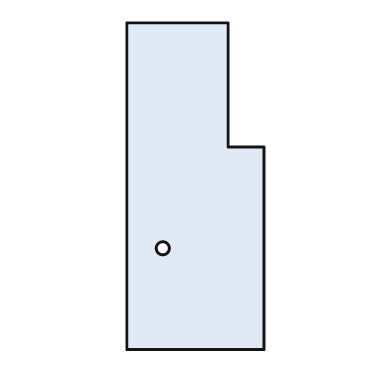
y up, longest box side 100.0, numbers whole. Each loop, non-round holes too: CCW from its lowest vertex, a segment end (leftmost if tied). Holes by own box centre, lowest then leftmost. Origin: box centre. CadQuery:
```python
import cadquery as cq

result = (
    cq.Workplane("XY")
    .moveTo(-21.0, -50.0)
    .lineTo(21.0, -50.0)
    .lineTo(21.0, 12.0)
    .lineTo(10.0, 12.0)
    .lineTo(10.0, 50.0)
    .lineTo(-21.0, 50.0)
    .close()
    .moveTo(-10.0, -19.0)
    .circle(2.0)
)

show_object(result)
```